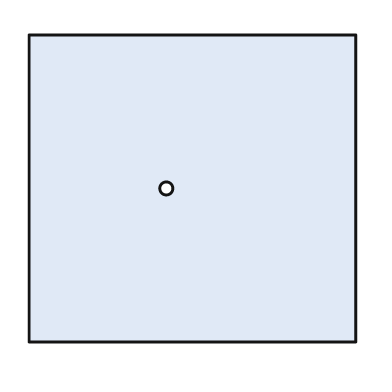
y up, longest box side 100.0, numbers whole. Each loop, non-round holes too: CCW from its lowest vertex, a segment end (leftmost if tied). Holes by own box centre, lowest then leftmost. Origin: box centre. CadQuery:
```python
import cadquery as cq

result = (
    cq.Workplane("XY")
    .moveTo(-50.0, -47.0)
    .lineTo(50.0, -47.0)
    .lineTo(50.0, 47.0)
    .lineTo(-50.0, 47.0)
    .close()
    .moveTo(-8.0, 0.0)
    .circle(2.0)
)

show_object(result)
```